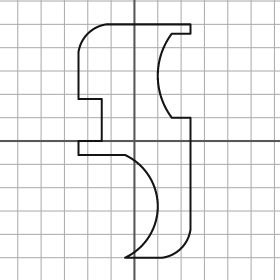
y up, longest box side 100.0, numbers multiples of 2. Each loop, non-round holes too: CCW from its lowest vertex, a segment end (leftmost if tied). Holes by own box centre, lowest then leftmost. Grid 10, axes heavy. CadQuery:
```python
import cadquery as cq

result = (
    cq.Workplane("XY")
    .moveTo(-4.0, -50.0)
    .lineTo(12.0, -50.0)
    .threePointArc((20.0, -46.0), (24.0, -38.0))
    .lineTo(24.0, 10.0)
    .lineTo(16.0, 10.0)
    .threePointArc((10.0, 28.0), (16.0, 46.0))
    .lineTo(24.0, 46.0)
    .lineTo(24.0, 50.0)
    .lineTo(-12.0, 50.0)
    .threePointArc((-20.0, 46.0), (-24.0, 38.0))
    .lineTo(-24.0, 18.0)
    .lineTo(-14.0, 18.0)
    .lineTo(-14.0, 0.0)
    .lineTo(-24.0, 0.0)
    .lineTo(-24.0, -6.0)
    .lineTo(-4.0, -6.0)
    .threePointArc((10.0, -28.0), (-4.0, -50.0))
    .close()
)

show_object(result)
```